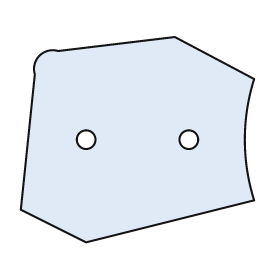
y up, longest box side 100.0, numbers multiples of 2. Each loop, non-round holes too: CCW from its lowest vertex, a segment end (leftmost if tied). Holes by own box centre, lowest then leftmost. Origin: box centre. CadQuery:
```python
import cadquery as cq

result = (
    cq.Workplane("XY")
    .moveTo(-22.0, -44.0)
    .lineTo(50.0, -26.0)
    .threePointArc((46.0, 0.0), (50.0, 26.0))
    .lineTo(16.0, 44.0)
    .lineTo(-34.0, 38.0)
    .threePointArc((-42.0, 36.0), (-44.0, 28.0))
    .lineTo(-50.0, -30.0)
    .close()
    .moveTo(-22.0, 0.0)
    .circle(4.0)
    .moveTo(22.0, 0.0)
    .circle(4.0)
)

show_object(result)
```